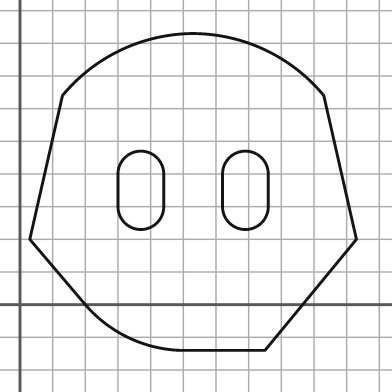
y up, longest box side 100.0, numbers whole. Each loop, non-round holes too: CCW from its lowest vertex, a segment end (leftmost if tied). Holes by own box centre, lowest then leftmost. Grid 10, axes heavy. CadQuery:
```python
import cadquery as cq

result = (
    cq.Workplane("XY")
    .moveTo(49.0, -14.0)
    .lineTo(75.0, -14.0)
    .lineTo(103.0, 20.0)
    .lineTo(93.0, 64.0)
    .threePointArc((75.0, 78.0), (53.0, 83.0))
    .threePointArc((31.0, 78.0), (13.0, 64.0))
    .lineTo(3.0, 20.0)
    .lineTo(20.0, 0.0)
    .threePointArc((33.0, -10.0), (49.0, -14.0))
    .close()
    .moveTo(30.0, 30.0)
    .threePointArc((37.0, 23.0), (44.0, 30.0))
    .lineTo(44.0, 40.0)
    .threePointArc((37.0, 47.0), (30.0, 40.0))
    .close()
    .moveTo(62.0, 30.0)
    .threePointArc((69.0, 23.0), (76.0, 30.0))
    .lineTo(76.0, 40.0)
    .threePointArc((69.0, 47.0), (62.0, 40.0))
    .close()
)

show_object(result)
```